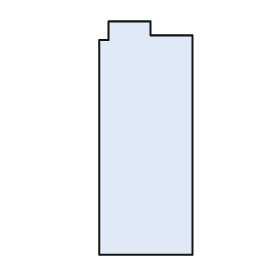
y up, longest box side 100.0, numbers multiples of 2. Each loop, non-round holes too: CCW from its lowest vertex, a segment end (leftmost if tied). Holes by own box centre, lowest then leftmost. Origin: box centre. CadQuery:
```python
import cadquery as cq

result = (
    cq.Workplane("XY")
    .moveTo(-20.0, -50.0)
    .lineTo(20.0, -50.0)
    .lineTo(20.0, 44.0)
    .lineTo(2.0, 44.0)
    .lineTo(2.0, 50.0)
    .lineTo(-16.0, 50.0)
    .lineTo(-16.0, 42.0)
    .lineTo(-20.0, 42.0)
    .close()
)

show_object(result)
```